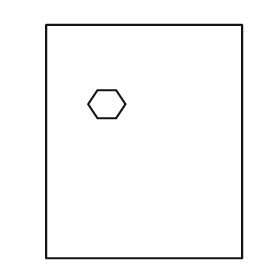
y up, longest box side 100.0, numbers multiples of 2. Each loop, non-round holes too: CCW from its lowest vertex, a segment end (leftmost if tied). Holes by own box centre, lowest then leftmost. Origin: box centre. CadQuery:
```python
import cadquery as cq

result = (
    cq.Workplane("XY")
    .moveTo(-42.0, -50.0)
    .lineTo(42.0, -50.0)
    .lineTo(42.0, 50.0)
    .lineTo(-42.0, 50.0)
    .close()
    .moveTo(-20.0, 10.0)
    .lineTo(-12.0, 10.0)
    .lineTo(-8.0, 16.0)
    .lineTo(-12.0, 22.0)
    .lineTo(-20.0, 22.0)
    .lineTo(-24.0, 16.0)
    .close()
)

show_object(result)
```